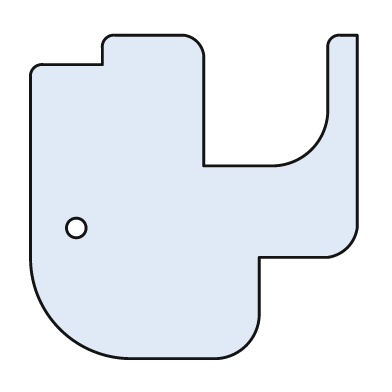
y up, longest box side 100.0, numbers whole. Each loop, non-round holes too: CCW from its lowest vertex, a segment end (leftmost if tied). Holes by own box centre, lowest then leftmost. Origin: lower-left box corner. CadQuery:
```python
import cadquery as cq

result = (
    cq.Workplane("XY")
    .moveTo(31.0, 0.0)
    .lineTo(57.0, 0.0)
    .threePointArc((66.0, 4.0), (70.0, 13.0))
    .lineTo(70.0, 31.0)
    .lineTo(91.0, 31.0)
    .threePointArc((97.0, 34.0), (100.0, 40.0))
    .lineTo(100.0, 99.0)
    .lineTo(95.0, 99.0)
    .threePointArc((92.0, 98.0), (91.0, 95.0))
    .lineTo(91.0, 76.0)
    .threePointArc((86.0, 64.0), (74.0, 59.0))
    .lineTo(53.0, 59.0)
    .lineTo(53.0, 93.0)
    .threePointArc((51.0, 97.0), (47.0, 99.0))
    .lineTo(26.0, 99.0)
    .threePointArc((23.0, 98.0), (22.0, 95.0))
    .lineTo(22.0, 90.0)
    .lineTo(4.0, 90.0)
    .threePointArc((1.0, 89.0), (0.0, 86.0))
    .lineTo(0.0, 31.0)
    .threePointArc((9.0, 9.0), (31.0, 0.0))
    .close()
    .moveTo(14.0, 40.0)
    .circle(3.0)
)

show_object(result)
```